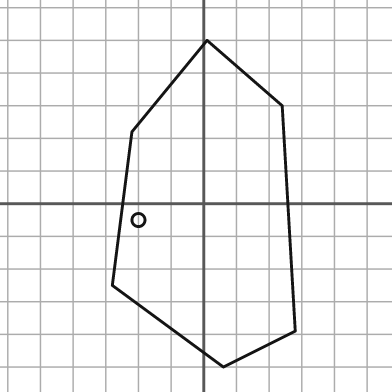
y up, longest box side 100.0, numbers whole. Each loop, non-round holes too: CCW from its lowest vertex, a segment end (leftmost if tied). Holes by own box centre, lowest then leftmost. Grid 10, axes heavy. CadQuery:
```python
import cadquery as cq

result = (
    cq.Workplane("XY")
    .moveTo(6.0, -50.0)
    .lineTo(28.0, -39.0)
    .lineTo(24.0, 30.0)
    .lineTo(1.0, 50.0)
    .lineTo(-22.0, 22.0)
    .lineTo(-28.0, -25.0)
    .close()
    .moveTo(-20.0, -5.0)
    .circle(2.0)
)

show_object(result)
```